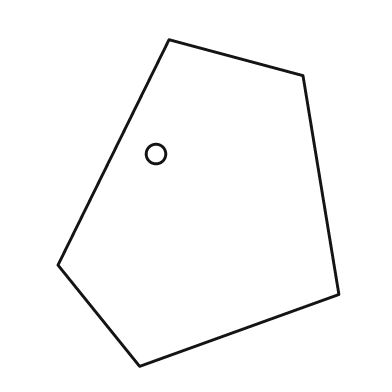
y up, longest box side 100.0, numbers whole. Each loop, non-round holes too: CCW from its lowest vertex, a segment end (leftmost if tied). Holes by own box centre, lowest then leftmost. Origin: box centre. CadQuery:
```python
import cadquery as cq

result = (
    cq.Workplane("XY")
    .moveTo(-18.0, -50.0)
    .lineTo(43.0, -28.0)
    .lineTo(32.0, 39.0)
    .lineTo(-9.0, 50.0)
    .lineTo(-43.0, -19.0)
    .close()
    .moveTo(-13.0, 15.0)
    .circle(3.0)
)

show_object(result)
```